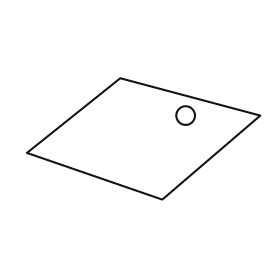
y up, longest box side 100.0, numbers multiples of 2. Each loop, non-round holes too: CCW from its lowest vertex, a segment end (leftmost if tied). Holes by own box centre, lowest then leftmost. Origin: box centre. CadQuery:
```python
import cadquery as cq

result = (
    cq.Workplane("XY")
    .moveTo(8.0, -26.0)
    .lineTo(50.0, 10.0)
    .lineTo(-10.0, 26.0)
    .lineTo(-50.0, -6.0)
    .close()
    .moveTo(18.0, 10.0)
    .circle(4.0)
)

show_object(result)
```